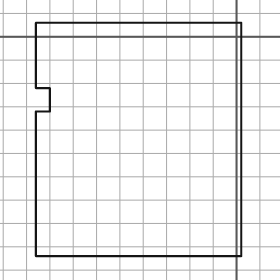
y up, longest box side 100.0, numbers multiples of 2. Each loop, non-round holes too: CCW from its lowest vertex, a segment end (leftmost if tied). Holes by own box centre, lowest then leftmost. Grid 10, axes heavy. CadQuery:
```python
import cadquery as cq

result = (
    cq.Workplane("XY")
    .moveTo(-86.0, -94.0)
    .lineTo(2.0, -94.0)
    .lineTo(2.0, 6.0)
    .lineTo(-86.0, 6.0)
    .lineTo(-86.0, -22.0)
    .lineTo(-80.0, -22.0)
    .lineTo(-80.0, -32.0)
    .lineTo(-86.0, -32.0)
    .close()
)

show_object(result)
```